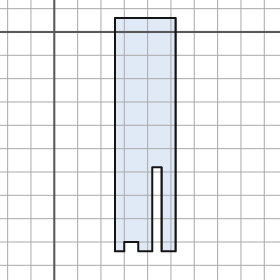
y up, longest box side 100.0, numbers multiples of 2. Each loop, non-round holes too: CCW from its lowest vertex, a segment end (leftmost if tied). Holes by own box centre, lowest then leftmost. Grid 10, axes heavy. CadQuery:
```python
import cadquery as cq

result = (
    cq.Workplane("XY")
    .moveTo(26.0, -94.0)
    .lineTo(30.0, -94.0)
    .lineTo(30.0, -90.0)
    .lineTo(36.0, -90.0)
    .lineTo(36.0, -94.0)
    .lineTo(42.0, -94.0)
    .lineTo(42.0, -58.0)
    .lineTo(46.0, -58.0)
    .lineTo(46.0, -94.0)
    .lineTo(52.0, -94.0)
    .lineTo(52.0, 6.0)
    .lineTo(26.0, 6.0)
    .close()
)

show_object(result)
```